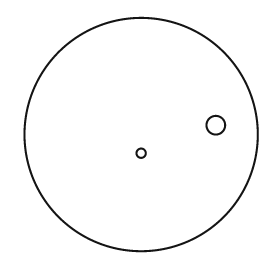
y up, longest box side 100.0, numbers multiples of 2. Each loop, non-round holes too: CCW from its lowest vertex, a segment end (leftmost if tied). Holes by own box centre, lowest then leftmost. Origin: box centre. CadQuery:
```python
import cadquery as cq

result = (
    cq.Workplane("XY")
    .moveTo(0.0, 0.0)
    .circle(50.0)
    .moveTo(0.0, -8.0)
    .circle(2.0)
    .moveTo(32.0, 4.0)
    .circle(4.0)
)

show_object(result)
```